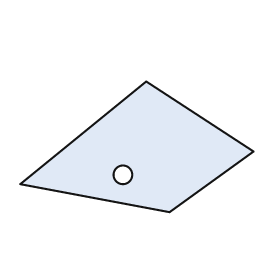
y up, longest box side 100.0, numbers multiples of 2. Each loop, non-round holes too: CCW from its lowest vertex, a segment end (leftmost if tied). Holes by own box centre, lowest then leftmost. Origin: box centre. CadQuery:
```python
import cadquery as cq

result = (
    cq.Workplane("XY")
    .moveTo(14.0, -28.0)
    .lineTo(50.0, -2.0)
    .lineTo(4.0, 28.0)
    .lineTo(-50.0, -16.0)
    .close()
    .moveTo(-6.0, -12.0)
    .circle(4.0)
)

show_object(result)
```